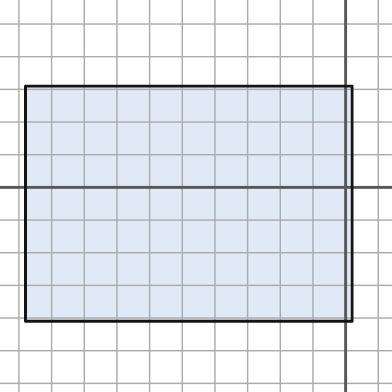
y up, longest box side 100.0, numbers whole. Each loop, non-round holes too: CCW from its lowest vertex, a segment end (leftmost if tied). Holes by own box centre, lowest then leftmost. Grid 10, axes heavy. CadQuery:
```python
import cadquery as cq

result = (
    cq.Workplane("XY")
    .moveTo(-98.0, -41.0)
    .lineTo(2.0, -41.0)
    .lineTo(2.0, 31.0)
    .lineTo(-98.0, 31.0)
    .close()
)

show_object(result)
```